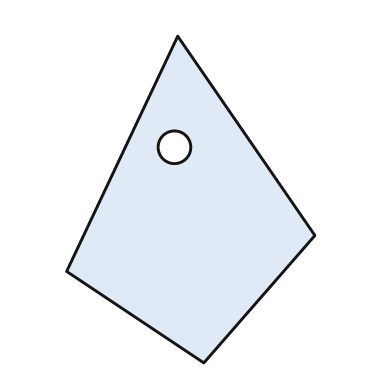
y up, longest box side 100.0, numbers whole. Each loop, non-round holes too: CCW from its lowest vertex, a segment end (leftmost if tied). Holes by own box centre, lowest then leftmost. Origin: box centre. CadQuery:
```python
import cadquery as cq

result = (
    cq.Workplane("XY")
    .moveTo(4.0, -50.0)
    .lineTo(38.0, -11.0)
    .lineTo(-4.0, 50.0)
    .lineTo(-38.0, -22.0)
    .close()
    .moveTo(-5.0, 16.0)
    .circle(5.0)
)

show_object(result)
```